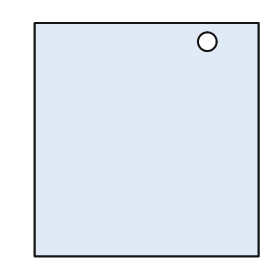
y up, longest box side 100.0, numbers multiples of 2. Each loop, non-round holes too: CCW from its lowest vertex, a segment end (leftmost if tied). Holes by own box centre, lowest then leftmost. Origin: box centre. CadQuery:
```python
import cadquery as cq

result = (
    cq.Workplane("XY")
    .moveTo(-48.0, -50.0)
    .lineTo(48.0, -50.0)
    .lineTo(48.0, 50.0)
    .lineTo(-48.0, 50.0)
    .close()
    .moveTo(26.0, 42.0)
    .circle(4.0)
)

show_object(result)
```